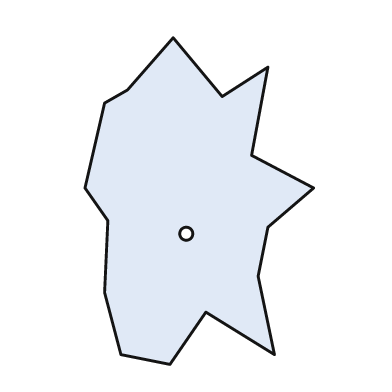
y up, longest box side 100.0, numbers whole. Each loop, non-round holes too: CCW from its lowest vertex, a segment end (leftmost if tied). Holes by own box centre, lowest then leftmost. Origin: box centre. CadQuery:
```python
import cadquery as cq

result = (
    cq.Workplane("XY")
    .moveTo(-9.0, -50.0)
    .lineTo(2.0, -34.0)
    .lineTo(23.0, -47.0)
    .lineTo(18.0, -23.0)
    .lineTo(21.0, -8.0)
    .lineTo(35.0, 4.0)
    .lineTo(16.0, 14.0)
    .lineTo(21.0, 41.0)
    .lineTo(7.0, 32.0)
    .lineTo(-8.0, 50.0)
    .lineTo(-22.0, 34.0)
    .lineTo(-29.0, 30.0)
    .lineTo(-35.0, 4.0)
    .lineTo(-28.0, -6.0)
    .lineTo(-29.0, -28.0)
    .lineTo(-24.0, -47.0)
    .close()
    .moveTo(-4.0, -10.0)
    .circle(2.0)
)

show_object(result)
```